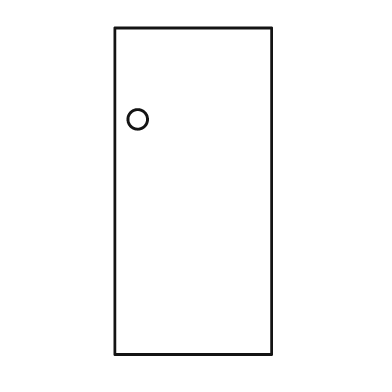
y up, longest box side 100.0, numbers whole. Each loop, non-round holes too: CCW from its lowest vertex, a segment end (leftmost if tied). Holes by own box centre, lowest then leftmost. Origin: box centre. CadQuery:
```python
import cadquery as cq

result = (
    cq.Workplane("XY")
    .moveTo(-24.0, -50.0)
    .lineTo(24.0, -50.0)
    .lineTo(24.0, 50.0)
    .lineTo(-24.0, 50.0)
    .close()
    .moveTo(-17.0, 22.0)
    .circle(3.0)
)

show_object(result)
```